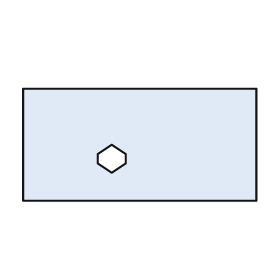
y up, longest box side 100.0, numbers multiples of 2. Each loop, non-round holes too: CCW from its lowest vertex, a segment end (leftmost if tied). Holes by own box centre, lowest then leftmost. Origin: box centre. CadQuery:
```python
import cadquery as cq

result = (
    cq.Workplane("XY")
    .moveTo(-50.0, -24.0)
    .lineTo(50.0, -24.0)
    .lineTo(50.0, 24.0)
    .lineTo(-50.0, 24.0)
    .close()
    .moveTo(-12.0, -12.0)
    .lineTo(-6.0, -8.0)
    .lineTo(-6.0, -4.0)
    .lineTo(-12.0, 0.0)
    .lineTo(-18.0, -4.0)
    .lineTo(-18.0, -8.0)
    .close()
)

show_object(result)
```